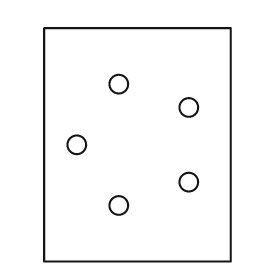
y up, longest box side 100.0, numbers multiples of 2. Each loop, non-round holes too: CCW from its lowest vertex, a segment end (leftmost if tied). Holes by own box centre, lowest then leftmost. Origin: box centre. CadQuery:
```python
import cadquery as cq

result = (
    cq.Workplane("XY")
    .moveTo(-40.0, -50.0)
    .lineTo(40.0, -50.0)
    .lineTo(40.0, 50.0)
    .lineTo(-40.0, 50.0)
    .close()
    .moveTo(-8.0, -26.0)
    .circle(4.0)
    .moveTo(22.0, -16.0)
    .circle(4.0)
    .moveTo(-26.0, 0.0)
    .circle(4.0)
    .moveTo(22.0, 16.0)
    .circle(4.0)
    .moveTo(-8.0, 26.0)
    .circle(4.0)
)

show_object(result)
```